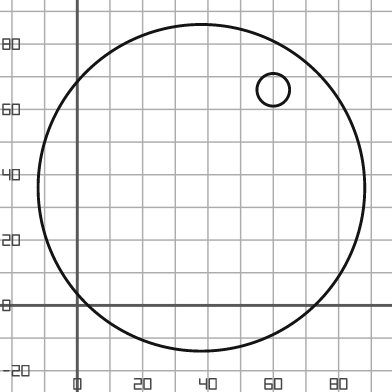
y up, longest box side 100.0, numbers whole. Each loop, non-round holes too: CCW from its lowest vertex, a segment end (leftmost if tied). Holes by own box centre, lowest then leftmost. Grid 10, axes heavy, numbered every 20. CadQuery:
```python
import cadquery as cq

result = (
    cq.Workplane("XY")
    .moveTo(38.0, 36.0)
    .circle(50.0)
    .moveTo(60.0, 66.0)
    .circle(5.0)
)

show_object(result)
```